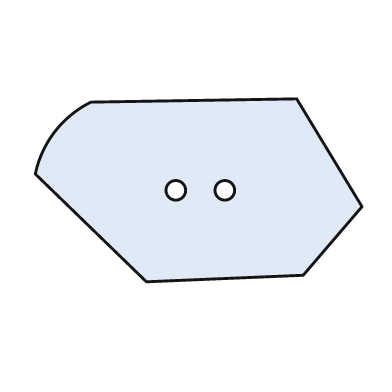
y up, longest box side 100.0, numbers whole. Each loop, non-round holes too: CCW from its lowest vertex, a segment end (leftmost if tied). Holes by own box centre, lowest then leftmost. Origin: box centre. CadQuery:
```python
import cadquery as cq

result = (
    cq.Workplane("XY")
    .moveTo(-16.0, -28.0)
    .lineTo(32.0, -26.0)
    .lineTo(50.0, -5.0)
    .lineTo(30.0, 28.0)
    .lineTo(-33.0, 27.0)
    .threePointArc((-44.0, 18.0), (-50.0, 5.0))
    .close()
    .moveTo(-7.0, 0.0)
    .circle(3.0)
    .moveTo(8.0, 0.0)
    .circle(3.0)
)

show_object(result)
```